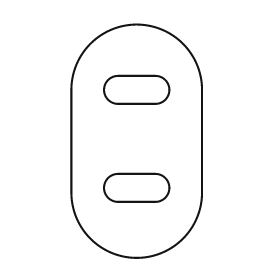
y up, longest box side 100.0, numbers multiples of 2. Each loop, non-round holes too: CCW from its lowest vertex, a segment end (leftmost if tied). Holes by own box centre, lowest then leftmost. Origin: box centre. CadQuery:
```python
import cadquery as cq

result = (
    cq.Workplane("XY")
    .moveTo(-28.0, -22.0)
    .threePointArc((0.0, -50.0), (28.0, -22.0))
    .lineTo(28.0, 22.0)
    .threePointArc((0.0, 50.0), (-28.0, 22.0))
    .close()
    .moveTo(-8.0, -26.0)
    .lineTo(8.0, -26.0)
    .threePointArc((14.0, -20.0), (8.0, -14.0))
    .lineTo(-8.0, -14.0)
    .threePointArc((-14.0, -20.0), (-8.0, -26.0))
    .close()
    .moveTo(-8.0, 16.0)
    .lineTo(8.0, 16.0)
    .threePointArc((14.0, 22.0), (8.0, 28.0))
    .lineTo(-8.0, 28.0)
    .threePointArc((-14.0, 22.0), (-8.0, 16.0))
    .close()
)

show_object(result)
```